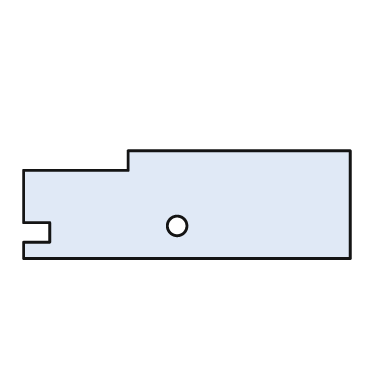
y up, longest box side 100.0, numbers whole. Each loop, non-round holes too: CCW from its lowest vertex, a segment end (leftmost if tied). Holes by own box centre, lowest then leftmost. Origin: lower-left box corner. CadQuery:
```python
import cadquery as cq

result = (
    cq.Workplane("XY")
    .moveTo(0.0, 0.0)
    .lineTo(100.0, 0.0)
    .lineTo(100.0, 33.0)
    .lineTo(32.0, 33.0)
    .lineTo(32.0, 27.0)
    .lineTo(0.0, 27.0)
    .lineTo(0.0, 11.0)
    .lineTo(8.0, 11.0)
    .lineTo(8.0, 5.0)
    .lineTo(0.0, 5.0)
    .close()
    .moveTo(47.0, 10.0)
    .circle(3.0)
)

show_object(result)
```